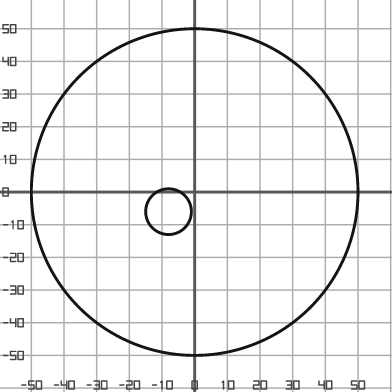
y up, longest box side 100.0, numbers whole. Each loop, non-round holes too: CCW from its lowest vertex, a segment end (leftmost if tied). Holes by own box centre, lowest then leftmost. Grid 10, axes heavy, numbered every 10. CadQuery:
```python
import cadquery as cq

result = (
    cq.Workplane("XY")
    .moveTo(0.0, 0.0)
    .circle(50.0)
    .moveTo(-8.0, -6.0)
    .circle(7.0)
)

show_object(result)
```